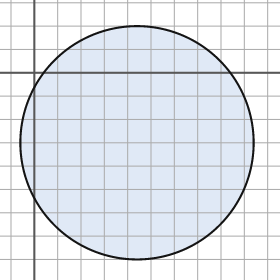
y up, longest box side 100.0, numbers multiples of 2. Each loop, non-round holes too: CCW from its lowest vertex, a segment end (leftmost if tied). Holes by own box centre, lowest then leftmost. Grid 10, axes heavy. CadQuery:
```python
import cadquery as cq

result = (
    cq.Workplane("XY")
    .moveTo(44.0, -30.0)
    .circle(50.0)
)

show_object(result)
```